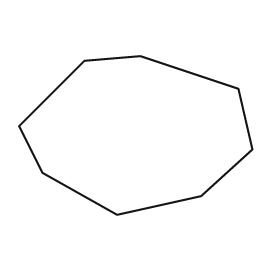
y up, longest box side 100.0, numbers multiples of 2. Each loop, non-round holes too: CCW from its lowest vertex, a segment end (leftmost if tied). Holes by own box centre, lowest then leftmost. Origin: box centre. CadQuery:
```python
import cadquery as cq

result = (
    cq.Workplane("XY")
    .moveTo(-8.0, -34.0)
    .lineTo(28.0, -26.0)
    .lineTo(50.0, -6.0)
    .lineTo(44.0, 20.0)
    .lineTo(2.0, 34.0)
    .lineTo(-22.0, 32.0)
    .lineTo(-50.0, 4.0)
    .lineTo(-40.0, -16.0)
    .close()
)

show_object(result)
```